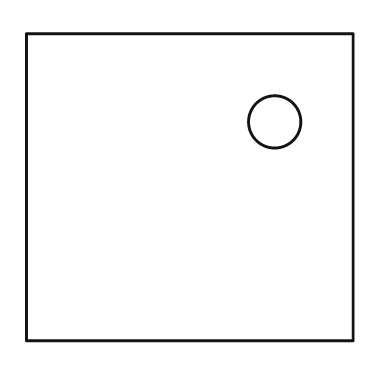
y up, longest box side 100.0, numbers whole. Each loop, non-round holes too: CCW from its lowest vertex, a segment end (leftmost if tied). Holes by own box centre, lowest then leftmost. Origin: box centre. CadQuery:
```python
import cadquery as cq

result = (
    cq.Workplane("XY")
    .moveTo(-50.0, -47.0)
    .lineTo(50.0, -47.0)
    .lineTo(50.0, 47.0)
    .lineTo(-50.0, 47.0)
    .close()
    .moveTo(26.0, 20.0)
    .circle(8.0)
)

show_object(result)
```